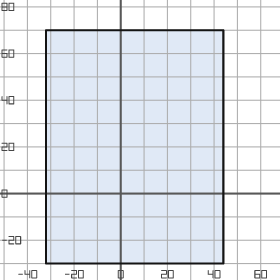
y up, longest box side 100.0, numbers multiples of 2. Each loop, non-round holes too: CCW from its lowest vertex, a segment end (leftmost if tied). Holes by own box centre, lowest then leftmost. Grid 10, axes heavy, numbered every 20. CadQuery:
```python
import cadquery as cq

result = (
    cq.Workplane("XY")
    .moveTo(-32.0, -30.0)
    .lineTo(44.0, -30.0)
    .lineTo(44.0, 70.0)
    .lineTo(-32.0, 70.0)
    .close()
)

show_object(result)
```